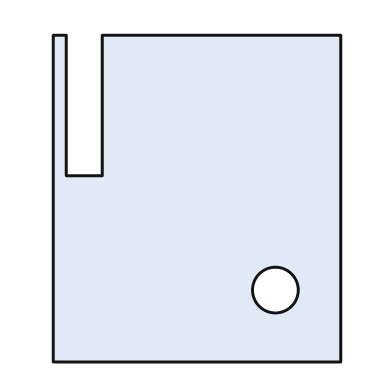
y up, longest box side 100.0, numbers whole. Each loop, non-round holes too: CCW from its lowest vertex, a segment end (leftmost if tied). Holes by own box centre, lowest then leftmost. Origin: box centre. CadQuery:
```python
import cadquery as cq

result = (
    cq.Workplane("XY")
    .moveTo(-44.0, -50.0)
    .lineTo(44.0, -50.0)
    .lineTo(44.0, 50.0)
    .lineTo(-29.0, 50.0)
    .lineTo(-29.0, 7.0)
    .lineTo(-40.0, 7.0)
    .lineTo(-40.0, 50.0)
    .lineTo(-44.0, 50.0)
    .close()
    .moveTo(24.0, -28.0)
    .circle(7.0)
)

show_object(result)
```